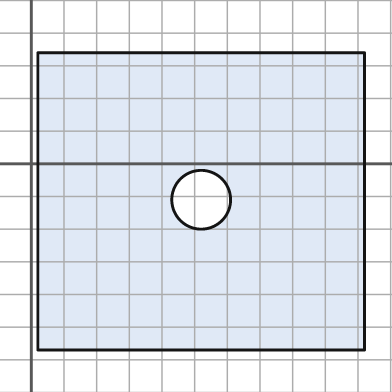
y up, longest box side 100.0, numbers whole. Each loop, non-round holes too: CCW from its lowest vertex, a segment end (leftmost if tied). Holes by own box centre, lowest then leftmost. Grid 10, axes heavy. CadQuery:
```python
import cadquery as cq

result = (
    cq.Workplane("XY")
    .moveTo(2.0, -57.0)
    .lineTo(102.0, -57.0)
    .lineTo(102.0, 34.0)
    .lineTo(2.0, 34.0)
    .close()
    .moveTo(52.0, -11.0)
    .circle(9.0)
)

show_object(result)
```